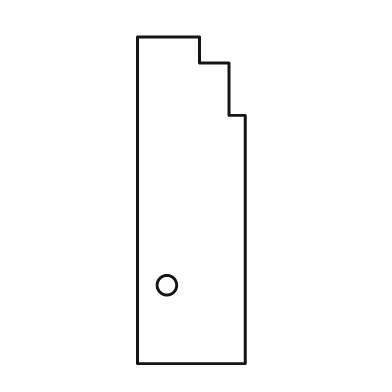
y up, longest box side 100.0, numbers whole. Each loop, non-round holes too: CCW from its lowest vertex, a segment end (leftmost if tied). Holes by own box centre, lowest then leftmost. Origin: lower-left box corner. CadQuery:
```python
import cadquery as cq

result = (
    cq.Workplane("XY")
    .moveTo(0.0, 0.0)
    .lineTo(33.0, 0.0)
    .lineTo(33.0, 76.0)
    .lineTo(28.0, 76.0)
    .lineTo(28.0, 92.0)
    .lineTo(19.0, 92.0)
    .lineTo(19.0, 100.0)
    .lineTo(0.0, 100.0)
    .close()
    .moveTo(9.0, 24.0)
    .circle(3.0)
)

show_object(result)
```